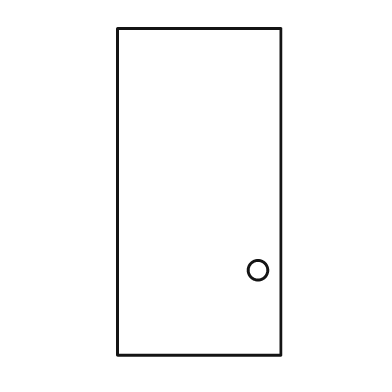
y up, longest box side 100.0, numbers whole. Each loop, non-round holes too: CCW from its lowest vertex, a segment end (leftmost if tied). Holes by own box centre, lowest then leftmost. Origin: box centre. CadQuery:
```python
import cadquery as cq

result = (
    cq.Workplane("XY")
    .moveTo(-25.0, -50.0)
    .lineTo(25.0, -50.0)
    .lineTo(25.0, 50.0)
    .lineTo(-25.0, 50.0)
    .close()
    .moveTo(18.0, -24.0)
    .circle(3.0)
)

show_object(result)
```